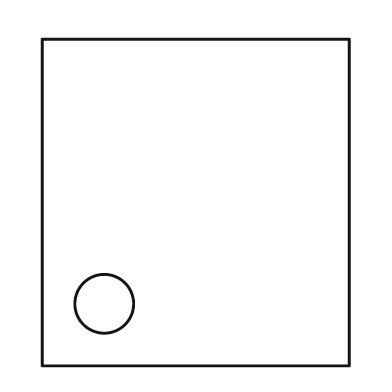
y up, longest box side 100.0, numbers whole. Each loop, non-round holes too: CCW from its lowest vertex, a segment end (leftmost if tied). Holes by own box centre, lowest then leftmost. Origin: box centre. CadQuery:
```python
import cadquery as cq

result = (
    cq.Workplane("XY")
    .moveTo(-47.0, -50.0)
    .lineTo(47.0, -50.0)
    .lineTo(47.0, 50.0)
    .lineTo(-47.0, 50.0)
    .close()
    .moveTo(-28.0, -31.0)
    .circle(9.0)
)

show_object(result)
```